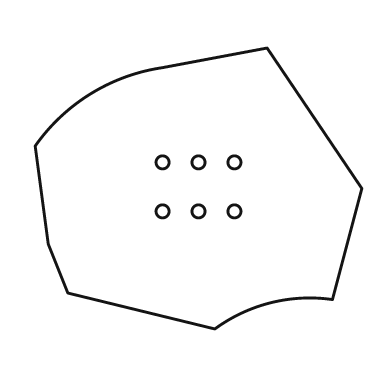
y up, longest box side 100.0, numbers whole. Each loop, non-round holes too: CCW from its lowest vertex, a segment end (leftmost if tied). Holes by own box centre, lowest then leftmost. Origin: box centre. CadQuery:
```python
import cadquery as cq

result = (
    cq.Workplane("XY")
    .moveTo(5.0, -43.0)
    .threePointArc((22.0, -35.0), (41.0, -34.0))
    .lineTo(50.0, 0.0)
    .lineTo(21.0, 43.0)
    .lineTo(-11.0, 37.0)
    .threePointArc((-33.0, 29.0), (-50.0, 13.0))
    .lineTo(-46.0, -17.0)
    .lineTo(-40.0, -32.0)
    .close()
    .moveTo(-11.0, -7.0)
    .circle(2.0)
    .moveTo(0.0, -7.0)
    .circle(2.0)
    .moveTo(11.0, -7.0)
    .circle(2.0)
    .moveTo(-11.0, 8.0)
    .circle(2.0)
    .moveTo(0.0, 8.0)
    .circle(2.0)
    .moveTo(11.0, 8.0)
    .circle(2.0)
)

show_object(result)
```